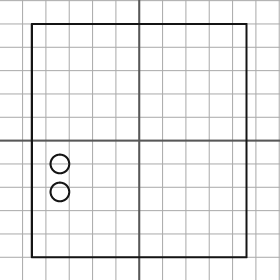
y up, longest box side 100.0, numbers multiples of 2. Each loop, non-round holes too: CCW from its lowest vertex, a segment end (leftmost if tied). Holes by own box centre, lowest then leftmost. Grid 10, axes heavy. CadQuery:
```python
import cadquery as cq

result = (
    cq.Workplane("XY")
    .moveTo(-46.0, -50.0)
    .lineTo(46.0, -50.0)
    .lineTo(46.0, 50.0)
    .lineTo(-46.0, 50.0)
    .close()
    .moveTo(-34.0, -22.0)
    .circle(4.0)
    .moveTo(-34.0, -10.0)
    .circle(4.0)
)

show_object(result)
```